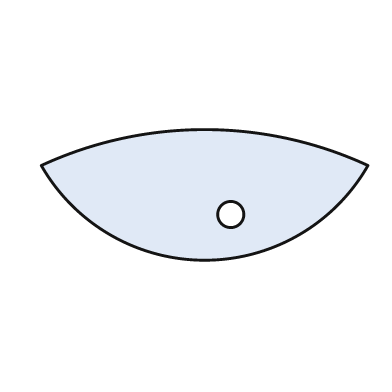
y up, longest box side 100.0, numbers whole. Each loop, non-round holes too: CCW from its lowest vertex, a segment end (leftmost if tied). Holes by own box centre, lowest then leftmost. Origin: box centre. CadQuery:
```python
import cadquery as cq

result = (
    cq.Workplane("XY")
    .moveTo(-50.0, 9.0)
    .threePointArc((0.0, -20.0), (50.0, 9.0))
    .threePointArc((0.0, 20.0), (-50.0, 9.0))
    .close()
    .moveTo(8.0, -6.0)
    .circle(4.0)
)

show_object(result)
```